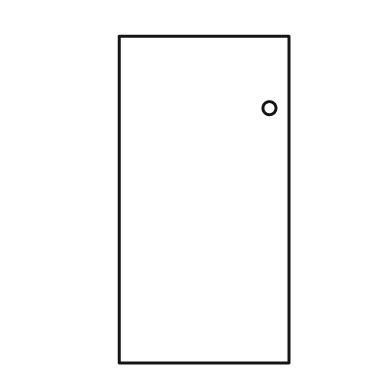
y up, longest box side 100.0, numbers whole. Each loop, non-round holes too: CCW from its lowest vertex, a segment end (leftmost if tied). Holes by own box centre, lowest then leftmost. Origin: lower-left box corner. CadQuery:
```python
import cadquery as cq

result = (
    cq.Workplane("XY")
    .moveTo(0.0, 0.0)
    .lineTo(52.0, 0.0)
    .lineTo(52.0, 100.0)
    .lineTo(0.0, 100.0)
    .close()
    .moveTo(46.0, 78.0)
    .circle(2.0)
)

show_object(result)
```